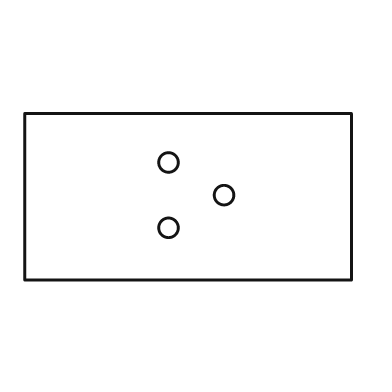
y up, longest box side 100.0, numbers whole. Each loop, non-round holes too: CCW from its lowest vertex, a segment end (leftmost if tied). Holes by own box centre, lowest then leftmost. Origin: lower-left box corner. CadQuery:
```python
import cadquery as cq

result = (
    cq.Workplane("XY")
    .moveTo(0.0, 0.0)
    .lineTo(100.0, 0.0)
    .lineTo(100.0, 51.0)
    .lineTo(0.0, 51.0)
    .close()
    .moveTo(44.0, 16.0)
    .circle(3.0)
    .moveTo(61.0, 26.0)
    .circle(3.0)
    .moveTo(44.0, 36.0)
    .circle(3.0)
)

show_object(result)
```